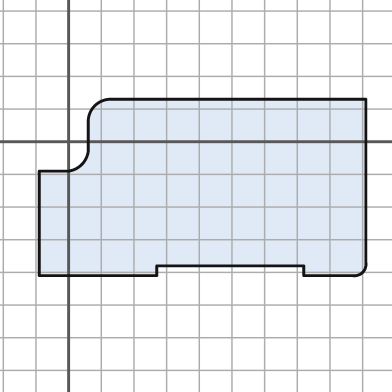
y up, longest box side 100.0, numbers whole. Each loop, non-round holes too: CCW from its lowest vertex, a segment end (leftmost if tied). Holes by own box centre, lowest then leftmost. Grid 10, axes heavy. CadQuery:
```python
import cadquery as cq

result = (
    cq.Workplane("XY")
    .moveTo(-9.0, -41.0)
    .lineTo(27.0, -41.0)
    .lineTo(27.0, -38.0)
    .lineTo(72.0, -38.0)
    .lineTo(72.0, -41.0)
    .lineTo(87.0, -41.0)
    .threePointArc((90.0, -40.0), (91.0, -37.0))
    .lineTo(91.0, 13.0)
    .lineTo(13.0, 13.0)
    .threePointArc((8.0, 11.0), (6.0, 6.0))
    .lineTo(6.0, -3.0)
    .threePointArc((4.0, -7.0), (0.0, -9.0))
    .lineTo(-9.0, -9.0)
    .close()
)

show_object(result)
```